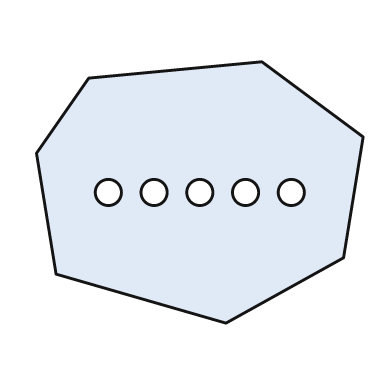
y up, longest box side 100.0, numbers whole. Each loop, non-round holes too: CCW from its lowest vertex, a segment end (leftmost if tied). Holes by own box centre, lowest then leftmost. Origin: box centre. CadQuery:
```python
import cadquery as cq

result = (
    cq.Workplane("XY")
    .moveTo(8.0, -40.0)
    .lineTo(44.0, -20.0)
    .lineTo(50.0, 17.0)
    .lineTo(19.0, 40.0)
    .lineTo(-34.0, 35.0)
    .lineTo(-50.0, 12.0)
    .lineTo(-44.0, -25.0)
    .close()
    .moveTo(-28.0, 0.0)
    .circle(4.0)
    .moveTo(-14.0, 0.0)
    .circle(4.0)
    .moveTo(0.0, 0.0)
    .circle(4.0)
    .moveTo(14.0, 0.0)
    .circle(4.0)
    .moveTo(28.0, 0.0)
    .circle(4.0)
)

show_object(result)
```